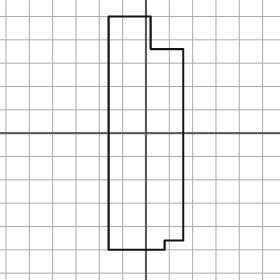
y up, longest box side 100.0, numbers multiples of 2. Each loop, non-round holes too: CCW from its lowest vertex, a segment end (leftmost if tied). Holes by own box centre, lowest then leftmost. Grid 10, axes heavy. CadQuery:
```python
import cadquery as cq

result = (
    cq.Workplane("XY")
    .moveTo(-16.0, -50.0)
    .lineTo(8.0, -50.0)
    .lineTo(8.0, -46.0)
    .lineTo(16.0, -46.0)
    .lineTo(16.0, 36.0)
    .lineTo(2.0, 36.0)
    .lineTo(2.0, 50.0)
    .lineTo(-16.0, 50.0)
    .close()
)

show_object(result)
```